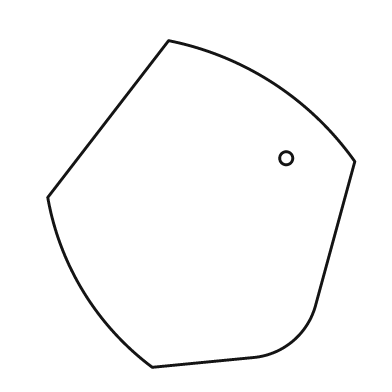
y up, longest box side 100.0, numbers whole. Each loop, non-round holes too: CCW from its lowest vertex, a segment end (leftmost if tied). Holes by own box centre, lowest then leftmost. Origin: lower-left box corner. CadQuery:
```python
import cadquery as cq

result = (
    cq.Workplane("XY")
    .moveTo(32.0, 0.0)
    .lineTo(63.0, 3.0)
    .threePointArc((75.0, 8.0), (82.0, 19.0))
    .lineTo(94.0, 63.0)
    .threePointArc((69.0, 87.0), (37.0, 100.0))
    .lineTo(0.0, 52.0)
    .threePointArc((11.0, 23.0), (32.0, 0.0))
    .close()
    .moveTo(73.0, 64.0)
    .circle(2.0)
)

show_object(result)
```